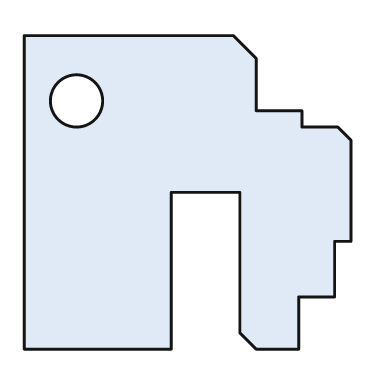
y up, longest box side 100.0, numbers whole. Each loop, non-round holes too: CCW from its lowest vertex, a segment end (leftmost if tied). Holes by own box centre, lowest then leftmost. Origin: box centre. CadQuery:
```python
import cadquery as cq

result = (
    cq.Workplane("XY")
    .moveTo(-50.0, -48.0)
    .lineTo(-5.0, -48.0)
    .lineTo(-5.0, 0.0)
    .lineTo(16.0, 0.0)
    .lineTo(16.0, -43.0)
    .lineTo(21.0, -48.0)
    .lineTo(34.0, -48.0)
    .lineTo(34.0, -32.0)
    .lineTo(45.0, -32.0)
    .lineTo(45.0, -15.0)
    .lineTo(50.0, -15.0)
    .lineTo(50.0, 16.0)
    .lineTo(46.0, 20.0)
    .lineTo(35.0, 20.0)
    .lineTo(35.0, 25.0)
    .lineTo(21.0, 25.0)
    .lineTo(21.0, 41.0)
    .lineTo(14.0, 48.0)
    .lineTo(-50.0, 48.0)
    .close()
    .moveTo(-34.0, 28.0)
    .circle(8.0)
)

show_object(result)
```